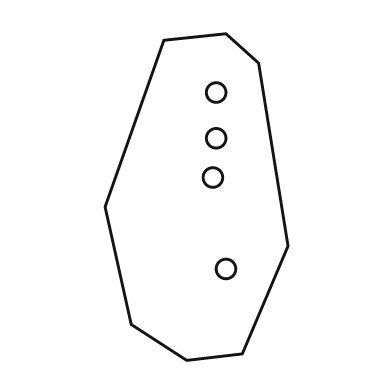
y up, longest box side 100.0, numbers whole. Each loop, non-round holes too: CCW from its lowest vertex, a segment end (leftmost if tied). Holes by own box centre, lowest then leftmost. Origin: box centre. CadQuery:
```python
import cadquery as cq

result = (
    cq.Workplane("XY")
    .moveTo(-3.0, -50.0)
    .lineTo(14.0, -48.0)
    .lineTo(28.0, -15.0)
    .lineTo(19.0, 41.0)
    .lineTo(9.0, 50.0)
    .lineTo(-10.0, 48.0)
    .lineTo(-28.0, -3.0)
    .lineTo(-20.0, -39.0)
    .close()
    .moveTo(9.0, -22.0)
    .circle(3.0)
    .moveTo(5.0, 6.0)
    .circle(3.0)
    .moveTo(6.0, 18.0)
    .circle(3.0)
    .moveTo(6.0, 32.0)
    .circle(3.0)
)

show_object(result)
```